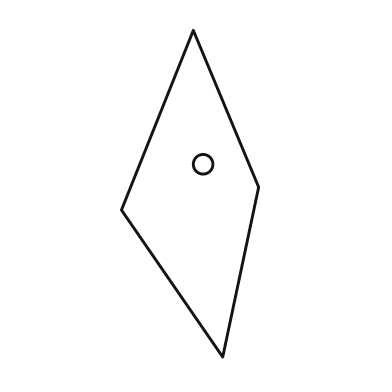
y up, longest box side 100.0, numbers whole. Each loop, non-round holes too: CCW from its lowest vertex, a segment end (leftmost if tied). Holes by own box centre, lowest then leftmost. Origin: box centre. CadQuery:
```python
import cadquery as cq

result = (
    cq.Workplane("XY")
    .moveTo(10.0, -50.0)
    .lineTo(21.0, 2.0)
    .lineTo(1.0, 50.0)
    .lineTo(-21.0, -5.0)
    .close()
    .moveTo(4.0, 9.0)
    .circle(3.0)
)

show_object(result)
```